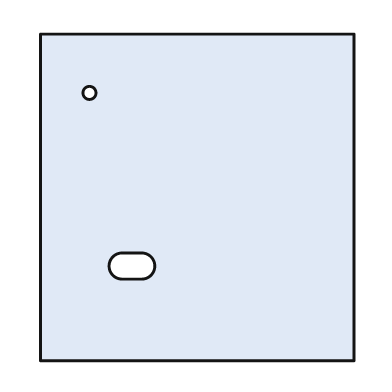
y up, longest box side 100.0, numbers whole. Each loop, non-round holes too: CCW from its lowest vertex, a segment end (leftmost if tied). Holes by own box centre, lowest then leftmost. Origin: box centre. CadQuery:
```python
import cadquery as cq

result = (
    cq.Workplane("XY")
    .moveTo(-48.0, -50.0)
    .lineTo(48.0, -50.0)
    .lineTo(48.0, 50.0)
    .lineTo(-48.0, 50.0)
    .close()
    .moveTo(-23.0, -25.0)
    .lineTo(-17.0, -25.0)
    .threePointArc((-13.0, -21.0), (-17.0, -17.0))
    .lineTo(-23.0, -17.0)
    .threePointArc((-27.0, -21.0), (-23.0, -25.0))
    .close()
    .moveTo(-33.0, 32.0)
    .circle(2.0)
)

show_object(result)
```